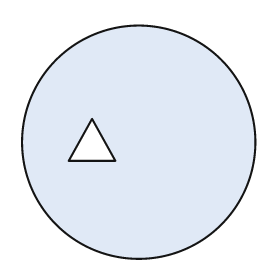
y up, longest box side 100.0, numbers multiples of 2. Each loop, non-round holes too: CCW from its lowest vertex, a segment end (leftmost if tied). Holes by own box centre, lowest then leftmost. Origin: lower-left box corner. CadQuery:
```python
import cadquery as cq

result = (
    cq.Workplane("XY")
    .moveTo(50.0, 50.0)
    .circle(50.0)
    .moveTo(20.0, 42.0)
    .lineTo(40.0, 42.0)
    .lineTo(30.0, 60.0)
    .close()
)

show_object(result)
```